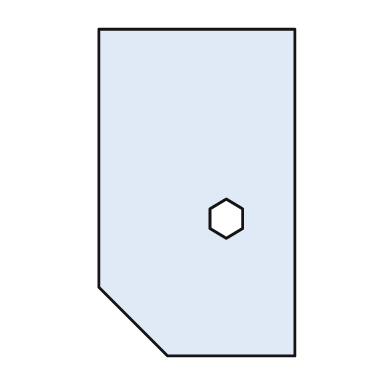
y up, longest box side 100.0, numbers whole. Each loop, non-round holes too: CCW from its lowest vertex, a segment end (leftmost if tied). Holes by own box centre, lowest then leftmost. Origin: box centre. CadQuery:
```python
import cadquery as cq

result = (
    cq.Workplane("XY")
    .moveTo(-9.0, -50.0)
    .lineTo(30.0, -50.0)
    .lineTo(30.0, 50.0)
    .lineTo(-30.0, 50.0)
    .lineTo(-30.0, -29.0)
    .close()
    .moveTo(9.0, -14.0)
    .lineTo(14.0, -11.0)
    .lineTo(14.0, -5.0)
    .lineTo(9.0, -2.0)
    .lineTo(4.0, -5.0)
    .lineTo(4.0, -11.0)
    .close()
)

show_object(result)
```